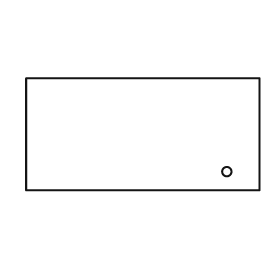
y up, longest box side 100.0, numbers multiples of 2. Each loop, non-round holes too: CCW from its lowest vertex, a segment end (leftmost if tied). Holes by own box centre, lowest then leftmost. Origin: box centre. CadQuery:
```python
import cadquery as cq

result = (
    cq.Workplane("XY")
    .moveTo(-50.0, -24.0)
    .lineTo(50.0, -24.0)
    .lineTo(50.0, 24.0)
    .lineTo(-50.0, 24.0)
    .close()
    .moveTo(36.0, -16.0)
    .circle(2.0)
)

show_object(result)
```